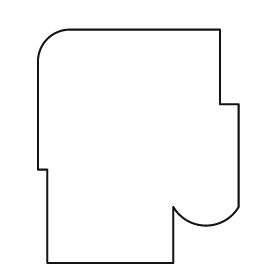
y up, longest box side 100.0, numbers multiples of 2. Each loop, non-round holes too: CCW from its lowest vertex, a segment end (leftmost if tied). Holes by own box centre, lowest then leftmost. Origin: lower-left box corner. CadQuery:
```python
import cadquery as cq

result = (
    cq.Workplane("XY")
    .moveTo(4.0, 0.0)
    .lineTo(58.0, 0.0)
    .lineTo(58.0, 24.0)
    .threePointArc((72.0, 16.0), (86.0, 24.0))
    .lineTo(86.0, 68.0)
    .lineTo(78.0, 68.0)
    .lineTo(78.0, 100.0)
    .lineTo(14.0, 100.0)
    .threePointArc((4.0, 96.0), (0.0, 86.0))
    .lineTo(0.0, 40.0)
    .lineTo(4.0, 40.0)
    .close()
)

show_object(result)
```